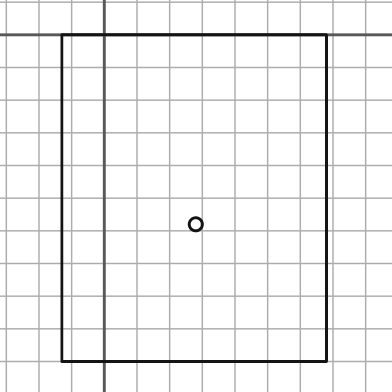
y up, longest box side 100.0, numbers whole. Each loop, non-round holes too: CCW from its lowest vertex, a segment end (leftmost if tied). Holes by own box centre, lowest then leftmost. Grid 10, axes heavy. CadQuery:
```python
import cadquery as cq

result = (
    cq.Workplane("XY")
    .moveTo(-13.0, -100.0)
    .lineTo(68.0, -100.0)
    .lineTo(68.0, 0.0)
    .lineTo(-13.0, 0.0)
    .close()
    .moveTo(28.0, -58.0)
    .circle(2.0)
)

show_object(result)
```